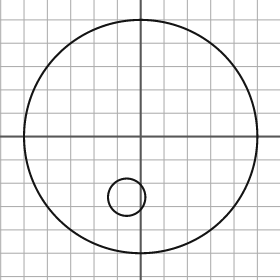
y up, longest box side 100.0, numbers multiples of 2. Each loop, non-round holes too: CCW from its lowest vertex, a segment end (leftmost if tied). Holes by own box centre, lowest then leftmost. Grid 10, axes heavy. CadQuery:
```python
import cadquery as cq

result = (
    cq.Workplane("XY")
    .moveTo(0.0, 0.0)
    .circle(50.0)
    .moveTo(-6.0, -26.0)
    .circle(8.0)
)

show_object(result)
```